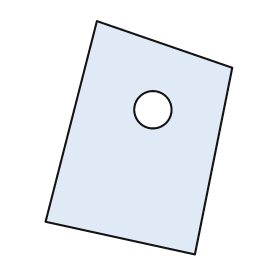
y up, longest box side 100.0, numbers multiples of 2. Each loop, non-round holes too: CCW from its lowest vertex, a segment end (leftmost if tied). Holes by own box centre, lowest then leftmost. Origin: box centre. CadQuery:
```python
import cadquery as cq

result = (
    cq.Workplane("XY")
    .moveTo(24.0, -50.0)
    .lineTo(40.0, 30.0)
    .lineTo(-18.0, 50.0)
    .lineTo(-40.0, -36.0)
    .close()
    .moveTo(6.0, 12.0)
    .circle(8.0)
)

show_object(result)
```